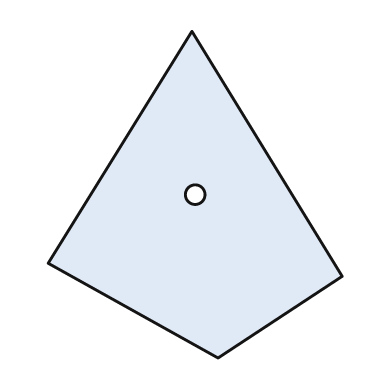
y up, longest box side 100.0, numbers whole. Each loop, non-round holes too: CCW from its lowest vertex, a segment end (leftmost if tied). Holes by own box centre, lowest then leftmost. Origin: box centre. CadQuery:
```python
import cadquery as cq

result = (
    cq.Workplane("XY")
    .moveTo(7.0, -50.0)
    .lineTo(45.0, -25.0)
    .lineTo(-1.0, 50.0)
    .lineTo(-45.0, -21.0)
    .close()
    .moveTo(0.0, 0.0)
    .circle(3.0)
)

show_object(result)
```